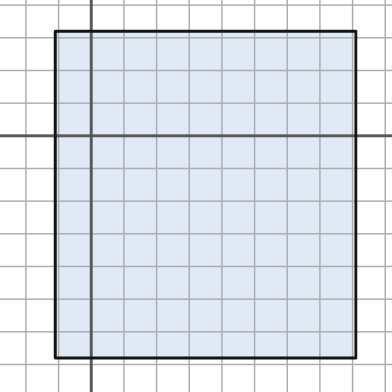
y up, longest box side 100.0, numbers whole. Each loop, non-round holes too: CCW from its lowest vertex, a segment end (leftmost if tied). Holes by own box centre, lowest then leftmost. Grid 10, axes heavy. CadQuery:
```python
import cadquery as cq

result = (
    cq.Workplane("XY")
    .moveTo(-11.0, -68.0)
    .lineTo(81.0, -68.0)
    .lineTo(81.0, 32.0)
    .lineTo(-11.0, 32.0)
    .close()
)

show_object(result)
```